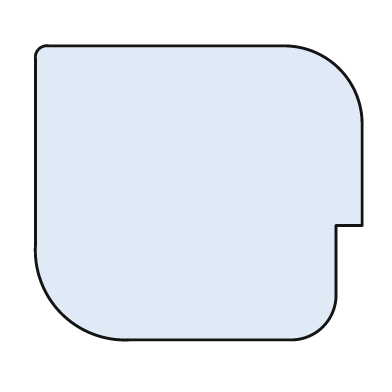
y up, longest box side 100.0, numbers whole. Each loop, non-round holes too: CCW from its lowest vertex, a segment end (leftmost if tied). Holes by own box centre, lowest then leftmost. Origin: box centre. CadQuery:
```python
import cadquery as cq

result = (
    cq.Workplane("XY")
    .moveTo(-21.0, -45.0)
    .lineTo(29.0, -45.0)
    .threePointArc((38.0, -41.0), (42.0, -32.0))
    .lineTo(42.0, -10.0)
    .lineTo(50.0, -10.0)
    .lineTo(50.0, 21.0)
    .threePointArc((43.0, 38.0), (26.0, 45.0))
    .lineTo(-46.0, 45.0)
    .threePointArc((-49.0, 44.0), (-50.0, 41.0))
    .lineTo(-50.0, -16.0)
    .threePointArc((-42.0, -37.0), (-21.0, -45.0))
    .close()
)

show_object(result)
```